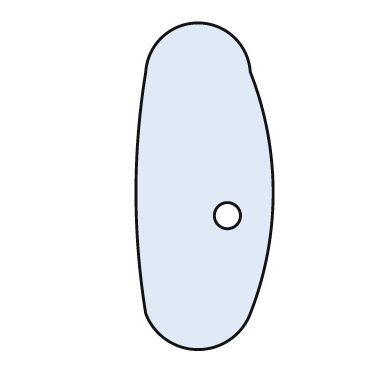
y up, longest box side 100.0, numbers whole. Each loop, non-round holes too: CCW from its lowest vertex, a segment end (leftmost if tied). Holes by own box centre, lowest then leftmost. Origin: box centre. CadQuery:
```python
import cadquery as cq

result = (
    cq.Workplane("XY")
    .moveTo(-18.0, -39.0)
    .threePointArc((-2.0, -50.0), (14.0, -39.0))
    .threePointArc((21.0, -2.0), (14.0, 35.0))
    .threePointArc((-2.0, 50.0), (-18.0, 35.0))
    .threePointArc((-21.0, -2.0), (-18.0, -39.0))
    .close()
    .moveTo(7.0, -9.0)
    .circle(4.0)
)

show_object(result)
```